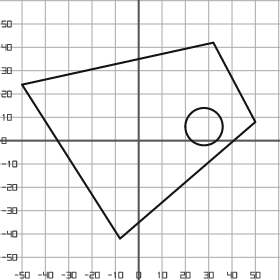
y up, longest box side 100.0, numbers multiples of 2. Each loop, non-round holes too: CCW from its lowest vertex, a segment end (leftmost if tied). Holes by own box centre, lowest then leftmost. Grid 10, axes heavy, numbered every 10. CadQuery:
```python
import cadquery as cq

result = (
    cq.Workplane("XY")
    .moveTo(-8.0, -42.0)
    .lineTo(50.0, 8.0)
    .lineTo(32.0, 42.0)
    .lineTo(-50.0, 24.0)
    .close()
    .moveTo(28.0, 6.0)
    .circle(8.0)
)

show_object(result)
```